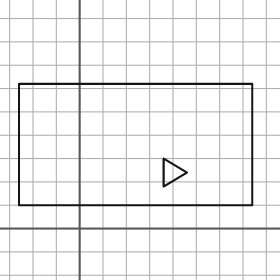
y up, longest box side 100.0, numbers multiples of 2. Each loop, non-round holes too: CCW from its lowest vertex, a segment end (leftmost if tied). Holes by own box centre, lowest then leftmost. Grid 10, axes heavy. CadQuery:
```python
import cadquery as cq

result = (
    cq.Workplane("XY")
    .moveTo(-26.0, 10.0)
    .lineTo(74.0, 10.0)
    .lineTo(74.0, 62.0)
    .lineTo(-26.0, 62.0)
    .close()
    .moveTo(36.0, 18.0)
    .lineTo(46.0, 24.0)
    .lineTo(36.0, 30.0)
    .close()
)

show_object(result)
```